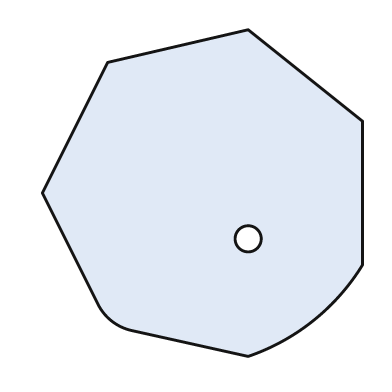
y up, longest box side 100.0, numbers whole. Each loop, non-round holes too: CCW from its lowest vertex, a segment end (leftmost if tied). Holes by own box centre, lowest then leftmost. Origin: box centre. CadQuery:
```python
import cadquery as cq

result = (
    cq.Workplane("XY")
    .moveTo(14.0, -50.0)
    .threePointArc((34.0, -39.0), (49.0, -22.0))
    .lineTo(49.0, 22.0)
    .lineTo(14.0, 50.0)
    .lineTo(-29.0, 40.0)
    .lineTo(-49.0, 0.0)
    .lineTo(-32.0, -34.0)
    .threePointArc((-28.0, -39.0), (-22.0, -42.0))
    .close()
    .moveTo(14.0, -14.0)
    .circle(4.0)
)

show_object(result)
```